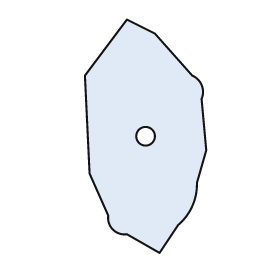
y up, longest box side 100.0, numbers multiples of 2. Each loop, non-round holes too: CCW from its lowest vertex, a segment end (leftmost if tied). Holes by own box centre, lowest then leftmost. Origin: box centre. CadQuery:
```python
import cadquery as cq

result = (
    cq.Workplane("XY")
    .moveTo(6.0, -50.0)
    .lineTo(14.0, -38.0)
    .threePointArc((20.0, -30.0), (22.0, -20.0))
    .lineTo(26.0, -6.0)
    .lineTo(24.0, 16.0)
    .threePointArc((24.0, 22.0), (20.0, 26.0))
    .lineTo(4.0, 44.0)
    .lineTo(-8.0, 50.0)
    .lineTo(-26.0, 26.0)
    .lineTo(-24.0, -16.0)
    .lineTo(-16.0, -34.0)
    .threePointArc((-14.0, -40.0), (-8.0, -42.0))
    .close()
    .moveTo(0.0, 0.0)
    .circle(4.0)
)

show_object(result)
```